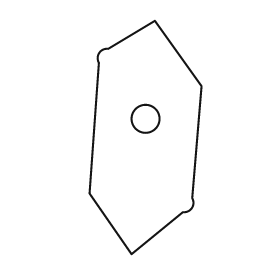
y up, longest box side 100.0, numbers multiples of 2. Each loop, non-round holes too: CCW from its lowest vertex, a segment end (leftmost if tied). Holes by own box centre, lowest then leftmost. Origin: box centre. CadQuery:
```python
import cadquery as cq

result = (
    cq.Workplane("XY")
    .moveTo(-6.0, -50.0)
    .lineTo(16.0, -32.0)
    .threePointArc((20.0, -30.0), (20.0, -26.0))
    .lineTo(24.0, 22.0)
    .lineTo(4.0, 50.0)
    .lineTo(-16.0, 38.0)
    .threePointArc((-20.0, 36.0), (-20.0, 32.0))
    .lineTo(-24.0, -24.0)
    .close()
    .moveTo(0.0, 8.0)
    .circle(6.0)
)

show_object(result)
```